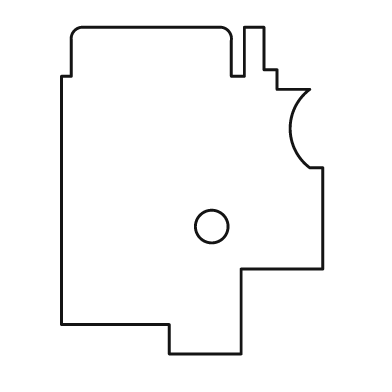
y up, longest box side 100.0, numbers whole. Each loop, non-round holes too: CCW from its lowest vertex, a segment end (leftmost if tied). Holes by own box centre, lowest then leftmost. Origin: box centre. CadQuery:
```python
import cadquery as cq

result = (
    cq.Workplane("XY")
    .moveTo(-7.0, -50.0)
    .lineTo(15.0, -50.0)
    .lineTo(15.0, -24.0)
    .lineTo(40.0, -24.0)
    .lineTo(40.0, 7.0)
    .lineTo(36.0, 7.0)
    .threePointArc((30.0, 19.0), (36.0, 31.0))
    .lineTo(26.0, 31.0)
    .lineTo(26.0, 37.0)
    .lineTo(22.0, 37.0)
    .lineTo(22.0, 50.0)
    .lineTo(16.0, 50.0)
    .lineTo(16.0, 35.0)
    .lineTo(12.0, 35.0)
    .lineTo(12.0, 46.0)
    .threePointArc((11.0, 49.0), (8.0, 50.0))
    .lineTo(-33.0, 50.0)
    .threePointArc((-36.0, 49.0), (-37.0, 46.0))
    .lineTo(-37.0, 35.0)
    .lineTo(-40.0, 35.0)
    .lineTo(-40.0, -41.0)
    .lineTo(-7.0, -41.0)
    .close()
    .moveTo(6.0, -11.0)
    .circle(5.0)
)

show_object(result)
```